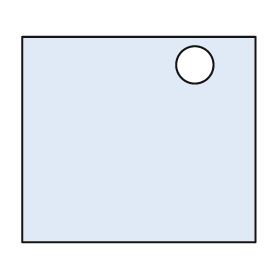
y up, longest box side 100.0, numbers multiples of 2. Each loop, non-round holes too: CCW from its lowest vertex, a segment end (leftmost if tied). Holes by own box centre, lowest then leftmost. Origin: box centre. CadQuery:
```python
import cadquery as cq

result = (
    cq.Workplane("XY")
    .moveTo(-50.0, -44.0)
    .lineTo(50.0, -44.0)
    .lineTo(50.0, 44.0)
    .lineTo(-50.0, 44.0)
    .close()
    .moveTo(24.0, 32.0)
    .circle(8.0)
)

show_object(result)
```